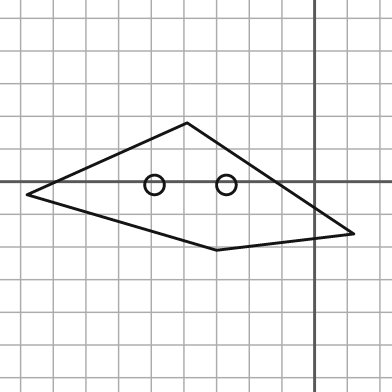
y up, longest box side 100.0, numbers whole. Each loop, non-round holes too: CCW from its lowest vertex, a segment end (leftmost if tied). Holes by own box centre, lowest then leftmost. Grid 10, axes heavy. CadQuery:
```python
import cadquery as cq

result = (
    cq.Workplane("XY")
    .moveTo(-30.0, -21.0)
    .lineTo(12.0, -16.0)
    .lineTo(-39.0, 18.0)
    .lineTo(-88.0, -4.0)
    .close()
    .moveTo(-49.0, -1.0)
    .circle(3.0)
    .moveTo(-27.0, -1.0)
    .circle(3.0)
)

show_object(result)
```